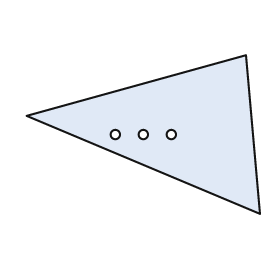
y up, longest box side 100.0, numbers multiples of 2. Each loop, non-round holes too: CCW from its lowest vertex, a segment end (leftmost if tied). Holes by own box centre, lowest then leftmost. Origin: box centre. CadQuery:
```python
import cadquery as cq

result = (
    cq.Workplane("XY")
    .moveTo(50.0, -34.0)
    .lineTo(44.0, 34.0)
    .lineTo(-50.0, 8.0)
    .close()
    .moveTo(-12.0, 0.0)
    .circle(2.0)
    .moveTo(0.0, 0.0)
    .circle(2.0)
    .moveTo(12.0, 0.0)
    .circle(2.0)
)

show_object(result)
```